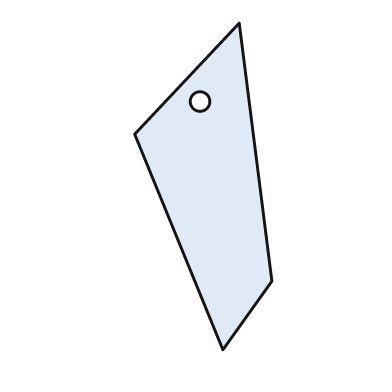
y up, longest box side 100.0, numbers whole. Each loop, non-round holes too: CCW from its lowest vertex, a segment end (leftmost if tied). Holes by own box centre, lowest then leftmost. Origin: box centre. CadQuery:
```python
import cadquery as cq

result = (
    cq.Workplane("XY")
    .moveTo(6.0, -50.0)
    .lineTo(21.0, -29.0)
    .lineTo(11.0, 50.0)
    .lineTo(-21.0, 16.0)
    .close()
    .moveTo(-1.0, 26.0)
    .circle(3.0)
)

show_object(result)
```